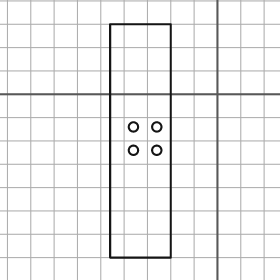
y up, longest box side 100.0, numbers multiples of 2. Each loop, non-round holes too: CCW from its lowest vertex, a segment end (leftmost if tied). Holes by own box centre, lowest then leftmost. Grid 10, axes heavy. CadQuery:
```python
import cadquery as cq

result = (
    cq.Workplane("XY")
    .moveTo(-46.0, -70.0)
    .lineTo(-20.0, -70.0)
    .lineTo(-20.0, 30.0)
    .lineTo(-46.0, 30.0)
    .close()
    .moveTo(-36.0, -24.0)
    .circle(2.0)
    .moveTo(-26.0, -24.0)
    .circle(2.0)
    .moveTo(-36.0, -14.0)
    .circle(2.0)
    .moveTo(-26.0, -14.0)
    .circle(2.0)
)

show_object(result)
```